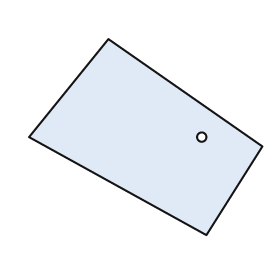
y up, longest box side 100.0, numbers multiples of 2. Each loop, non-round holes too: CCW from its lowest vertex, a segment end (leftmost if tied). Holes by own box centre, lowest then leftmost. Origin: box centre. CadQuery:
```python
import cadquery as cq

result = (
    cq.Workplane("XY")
    .moveTo(26.0, -42.0)
    .lineTo(50.0, -4.0)
    .lineTo(-16.0, 42.0)
    .lineTo(-50.0, 0.0)
    .close()
    .moveTo(24.0, 0.0)
    .circle(2.0)
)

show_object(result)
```